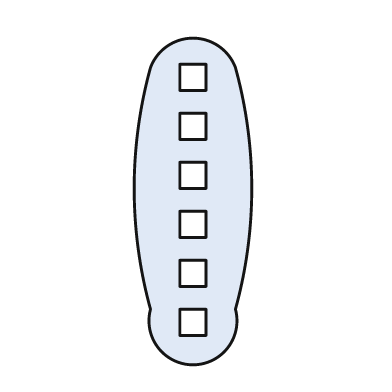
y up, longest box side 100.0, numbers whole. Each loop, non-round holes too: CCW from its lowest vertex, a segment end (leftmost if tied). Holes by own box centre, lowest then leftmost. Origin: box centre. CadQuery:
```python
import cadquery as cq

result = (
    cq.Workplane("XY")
    .moveTo(-13.0, -33.0)
    .threePointArc((0.0, -50.0), (13.0, -33.0))
    .threePointArc((18.0, 4.0), (13.0, 41.0))
    .threePointArc((0.0, 50.0), (-13.0, 41.0))
    .threePointArc((-18.0, 4.0), (-13.0, -33.0))
    .close()
    .moveTo(-4.0, -41.0)
    .lineTo(4.0, -41.0)
    .lineTo(4.0, -33.0)
    .lineTo(-4.0, -33.0)
    .close()
    .moveTo(-4.0, -26.0)
    .lineTo(4.0, -26.0)
    .lineTo(4.0, -18.0)
    .lineTo(-4.0, -18.0)
    .close()
    .moveTo(-4.0, -11.0)
    .lineTo(4.0, -11.0)
    .lineTo(4.0, -3.0)
    .lineTo(-4.0, -3.0)
    .close()
    .moveTo(-4.0, 4.0)
    .lineTo(4.0, 4.0)
    .lineTo(4.0, 12.0)
    .lineTo(-4.0, 12.0)
    .close()
    .moveTo(-4.0, 19.0)
    .lineTo(4.0, 19.0)
    .lineTo(4.0, 27.0)
    .lineTo(-4.0, 27.0)
    .close()
    .moveTo(-4.0, 34.0)
    .lineTo(4.0, 34.0)
    .lineTo(4.0, 42.0)
    .lineTo(-4.0, 42.0)
    .close()
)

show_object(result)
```